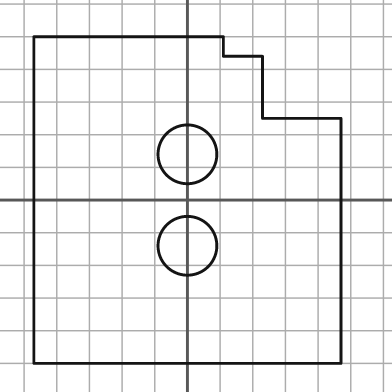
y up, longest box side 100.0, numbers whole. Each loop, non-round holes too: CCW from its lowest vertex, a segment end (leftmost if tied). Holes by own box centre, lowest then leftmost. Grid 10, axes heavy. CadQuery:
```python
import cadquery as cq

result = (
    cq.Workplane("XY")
    .moveTo(-47.0, -50.0)
    .lineTo(47.0, -50.0)
    .lineTo(47.0, 25.0)
    .lineTo(23.0, 25.0)
    .lineTo(23.0, 44.0)
    .lineTo(11.0, 44.0)
    .lineTo(11.0, 50.0)
    .lineTo(-47.0, 50.0)
    .close()
    .moveTo(0.0, -14.0)
    .circle(9.0)
    .moveTo(0.0, 14.0)
    .circle(9.0)
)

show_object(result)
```